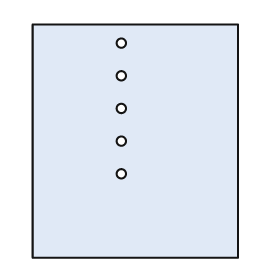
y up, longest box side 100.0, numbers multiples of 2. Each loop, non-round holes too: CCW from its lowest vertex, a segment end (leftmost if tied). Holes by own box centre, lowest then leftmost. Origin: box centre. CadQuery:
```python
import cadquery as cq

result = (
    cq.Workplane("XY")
    .moveTo(-44.0, -50.0)
    .lineTo(44.0, -50.0)
    .lineTo(44.0, 50.0)
    .lineTo(-44.0, 50.0)
    .close()
    .moveTo(-6.0, -14.0)
    .circle(2.0)
    .moveTo(-6.0, 0.0)
    .circle(2.0)
    .moveTo(-6.0, 14.0)
    .circle(2.0)
    .moveTo(-6.0, 28.0)
    .circle(2.0)
    .moveTo(-6.0, 42.0)
    .circle(2.0)
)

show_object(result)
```